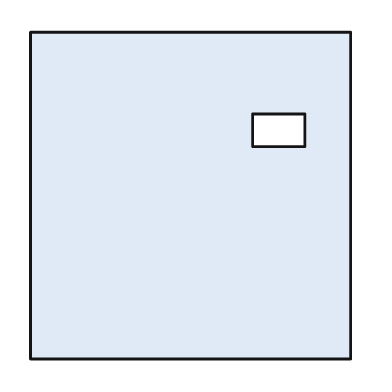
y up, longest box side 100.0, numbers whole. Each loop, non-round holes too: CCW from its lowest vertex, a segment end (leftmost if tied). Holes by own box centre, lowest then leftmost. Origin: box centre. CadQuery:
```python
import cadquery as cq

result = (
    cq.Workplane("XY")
    .moveTo(-49.0, -50.0)
    .lineTo(49.0, -50.0)
    .lineTo(49.0, 50.0)
    .lineTo(-49.0, 50.0)
    .close()
    .moveTo(19.0, 15.0)
    .lineTo(35.0, 15.0)
    .lineTo(35.0, 25.0)
    .lineTo(19.0, 25.0)
    .close()
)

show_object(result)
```